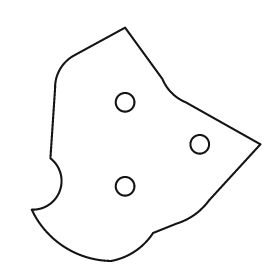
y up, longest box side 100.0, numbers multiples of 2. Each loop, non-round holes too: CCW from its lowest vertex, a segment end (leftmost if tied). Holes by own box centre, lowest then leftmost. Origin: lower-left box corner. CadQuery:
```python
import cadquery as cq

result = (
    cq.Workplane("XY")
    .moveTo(34.0, 0.0)
    .threePointArc((44.0, 4.0), (52.0, 12.0))
    .lineTo(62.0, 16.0)
    .threePointArc((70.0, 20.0), (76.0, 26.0))
    .lineTo(98.0, 50.0)
    .lineTo(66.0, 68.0)
    .threePointArc((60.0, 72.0), (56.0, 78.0))
    .lineTo(40.0, 100.0)
    .lineTo(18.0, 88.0)
    .threePointArc((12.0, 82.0), (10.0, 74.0))
    .lineTo(8.0, 44.0)
    .threePointArc((12.0, 30.0), (0.0, 22.0))
    .threePointArc((14.0, 6.0), (34.0, 0.0))
    .close()
    .moveTo(40.0, 32.0)
    .circle(4.0)
    .moveTo(72.0, 50.0)
    .circle(4.0)
    .moveTo(40.0, 68.0)
    .circle(4.0)
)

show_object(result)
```